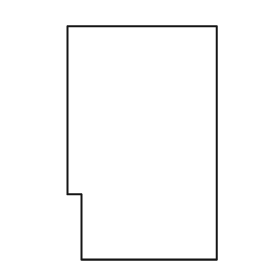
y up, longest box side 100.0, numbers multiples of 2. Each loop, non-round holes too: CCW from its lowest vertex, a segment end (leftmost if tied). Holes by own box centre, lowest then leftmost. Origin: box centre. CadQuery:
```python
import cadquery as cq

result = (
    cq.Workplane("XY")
    .moveTo(-26.0, -50.0)
    .lineTo(32.0, -50.0)
    .lineTo(32.0, 50.0)
    .lineTo(-32.0, 50.0)
    .lineTo(-32.0, -22.0)
    .lineTo(-26.0, -22.0)
    .close()
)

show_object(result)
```